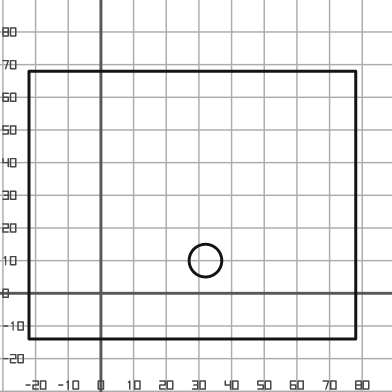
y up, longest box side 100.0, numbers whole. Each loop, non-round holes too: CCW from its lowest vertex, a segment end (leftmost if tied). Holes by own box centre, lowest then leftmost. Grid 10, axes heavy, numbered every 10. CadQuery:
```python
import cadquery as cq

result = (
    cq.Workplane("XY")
    .moveTo(-22.0, -14.0)
    .lineTo(78.0, -14.0)
    .lineTo(78.0, 68.0)
    .lineTo(-22.0, 68.0)
    .close()
    .moveTo(32.0, 10.0)
    .circle(5.0)
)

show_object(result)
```